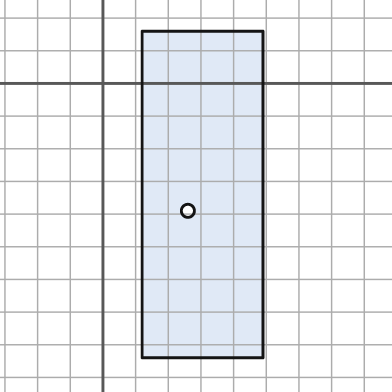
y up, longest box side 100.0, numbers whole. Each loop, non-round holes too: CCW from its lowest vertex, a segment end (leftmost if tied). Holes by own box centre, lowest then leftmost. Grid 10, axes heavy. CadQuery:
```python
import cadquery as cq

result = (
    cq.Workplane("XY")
    .moveTo(12.0, -84.0)
    .lineTo(49.0, -84.0)
    .lineTo(49.0, 16.0)
    .lineTo(12.0, 16.0)
    .close()
    .moveTo(26.0, -39.0)
    .circle(2.0)
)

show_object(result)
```